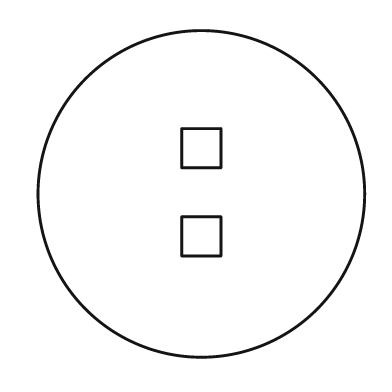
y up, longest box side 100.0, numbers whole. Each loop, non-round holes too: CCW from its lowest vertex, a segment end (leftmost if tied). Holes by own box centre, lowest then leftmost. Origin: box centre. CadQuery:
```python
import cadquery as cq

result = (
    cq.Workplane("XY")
    .moveTo(0.0, 0.0)
    .circle(50.0)
    .moveTo(-6.0, -19.0)
    .lineTo(6.0, -19.0)
    .lineTo(6.0, -7.0)
    .lineTo(-6.0, -7.0)
    .close()
    .moveTo(-6.0, 8.0)
    .lineTo(6.0, 8.0)
    .lineTo(6.0, 20.0)
    .lineTo(-6.0, 20.0)
    .close()
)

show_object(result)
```